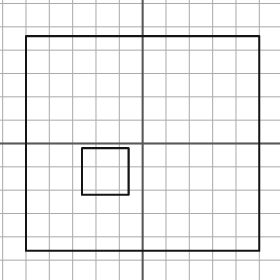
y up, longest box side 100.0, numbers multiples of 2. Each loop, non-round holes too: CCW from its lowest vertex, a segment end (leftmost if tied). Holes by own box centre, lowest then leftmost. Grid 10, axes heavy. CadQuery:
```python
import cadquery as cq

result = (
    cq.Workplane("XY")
    .moveTo(-50.0, -46.0)
    .lineTo(50.0, -46.0)
    .lineTo(50.0, 46.0)
    .lineTo(-50.0, 46.0)
    .close()
    .moveTo(-26.0, -22.0)
    .lineTo(-6.0, -22.0)
    .lineTo(-6.0, -2.0)
    .lineTo(-26.0, -2.0)
    .close()
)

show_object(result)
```